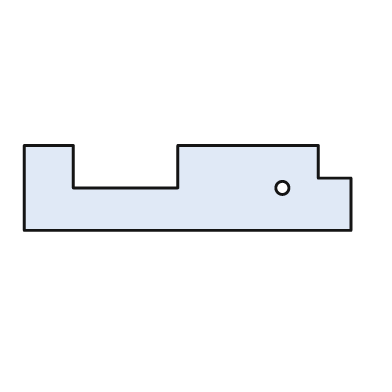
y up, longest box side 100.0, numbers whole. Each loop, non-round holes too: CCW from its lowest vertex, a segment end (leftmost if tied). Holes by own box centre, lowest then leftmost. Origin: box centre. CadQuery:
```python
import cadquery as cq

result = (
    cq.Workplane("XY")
    .moveTo(-50.0, -13.0)
    .lineTo(50.0, -13.0)
    .lineTo(50.0, 3.0)
    .lineTo(40.0, 3.0)
    .lineTo(40.0, 13.0)
    .lineTo(-3.0, 13.0)
    .lineTo(-3.0, 0.0)
    .lineTo(-35.0, 0.0)
    .lineTo(-35.0, 13.0)
    .lineTo(-50.0, 13.0)
    .close()
    .moveTo(29.0, 0.0)
    .circle(2.0)
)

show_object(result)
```